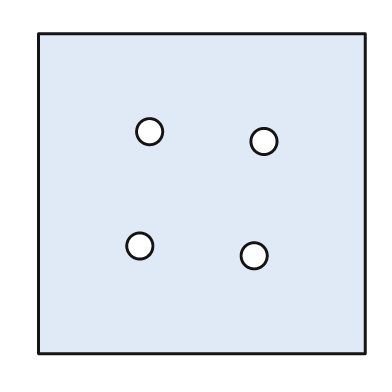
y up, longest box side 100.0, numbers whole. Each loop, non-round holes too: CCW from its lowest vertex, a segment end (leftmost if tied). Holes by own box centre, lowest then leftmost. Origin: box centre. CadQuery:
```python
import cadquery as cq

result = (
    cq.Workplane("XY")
    .moveTo(-50.0, -49.0)
    .lineTo(50.0, -49.0)
    .lineTo(50.0, 49.0)
    .lineTo(-50.0, 49.0)
    .close()
    .moveTo(16.0, -19.0)
    .circle(4.0)
    .moveTo(-19.0, -16.0)
    .circle(4.0)
    .moveTo(19.0, 16.0)
    .circle(4.0)
    .moveTo(-16.0, 19.0)
    .circle(4.0)
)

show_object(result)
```